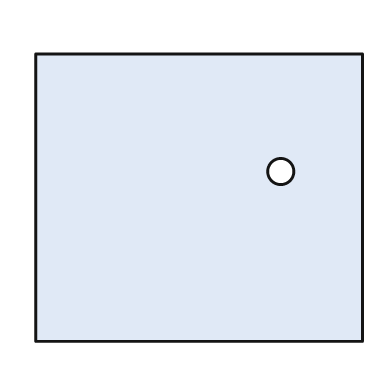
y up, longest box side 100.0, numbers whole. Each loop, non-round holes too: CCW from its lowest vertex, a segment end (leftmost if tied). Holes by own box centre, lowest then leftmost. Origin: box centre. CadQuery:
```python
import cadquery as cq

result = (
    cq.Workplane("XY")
    .moveTo(-50.0, -44.0)
    .lineTo(50.0, -44.0)
    .lineTo(50.0, 44.0)
    .lineTo(-50.0, 44.0)
    .close()
    .moveTo(25.0, 8.0)
    .circle(4.0)
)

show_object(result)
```